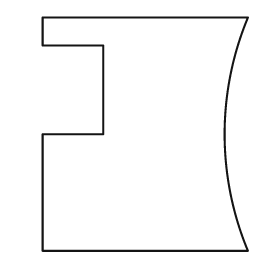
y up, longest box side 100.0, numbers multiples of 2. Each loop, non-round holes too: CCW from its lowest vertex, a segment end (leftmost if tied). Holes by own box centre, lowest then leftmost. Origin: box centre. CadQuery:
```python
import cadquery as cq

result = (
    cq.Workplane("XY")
    .moveTo(-44.0, -50.0)
    .lineTo(44.0, -50.0)
    .threePointArc((34.0, 0.0), (44.0, 50.0))
    .lineTo(-44.0, 50.0)
    .lineTo(-44.0, 38.0)
    .lineTo(-18.0, 38.0)
    .lineTo(-18.0, 0.0)
    .lineTo(-44.0, 0.0)
    .close()
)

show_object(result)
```